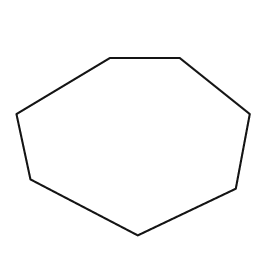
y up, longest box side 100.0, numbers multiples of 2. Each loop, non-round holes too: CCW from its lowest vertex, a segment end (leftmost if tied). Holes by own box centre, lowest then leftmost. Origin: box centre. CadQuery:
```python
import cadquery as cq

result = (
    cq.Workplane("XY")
    .moveTo(2.0, -38.0)
    .lineTo(44.0, -18.0)
    .lineTo(50.0, 14.0)
    .lineTo(20.0, 38.0)
    .lineTo(-10.0, 38.0)
    .lineTo(-50.0, 14.0)
    .lineTo(-44.0, -14.0)
    .close()
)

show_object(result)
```